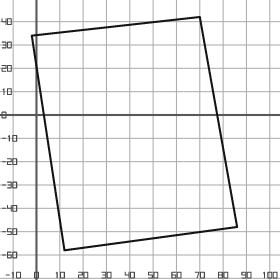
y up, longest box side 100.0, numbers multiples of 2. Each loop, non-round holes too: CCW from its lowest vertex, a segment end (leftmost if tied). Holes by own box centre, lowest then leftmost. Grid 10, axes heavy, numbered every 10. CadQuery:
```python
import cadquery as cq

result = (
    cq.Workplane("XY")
    .moveTo(12.0, -58.0)
    .lineTo(86.0, -48.0)
    .lineTo(70.0, 42.0)
    .lineTo(-2.0, 34.0)
    .close()
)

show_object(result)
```